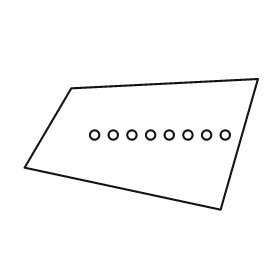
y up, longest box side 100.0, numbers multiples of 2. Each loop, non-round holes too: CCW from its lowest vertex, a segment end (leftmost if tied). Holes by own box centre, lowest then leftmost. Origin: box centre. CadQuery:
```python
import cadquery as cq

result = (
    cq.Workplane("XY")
    .moveTo(34.0, -28.0)
    .lineTo(50.0, 28.0)
    .lineTo(-30.0, 24.0)
    .lineTo(-50.0, -10.0)
    .close()
    .moveTo(-20.0, 4.0)
    .circle(2.0)
    .moveTo(-12.0, 4.0)
    .circle(2.0)
    .moveTo(-4.0, 4.0)
    .circle(2.0)
    .moveTo(4.0, 4.0)
    .circle(2.0)
    .moveTo(12.0, 4.0)
    .circle(2.0)
    .moveTo(20.0, 4.0)
    .circle(2.0)
    .moveTo(28.0, 4.0)
    .circle(2.0)
    .moveTo(36.0, 4.0)
    .circle(2.0)
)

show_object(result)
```